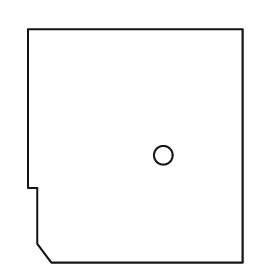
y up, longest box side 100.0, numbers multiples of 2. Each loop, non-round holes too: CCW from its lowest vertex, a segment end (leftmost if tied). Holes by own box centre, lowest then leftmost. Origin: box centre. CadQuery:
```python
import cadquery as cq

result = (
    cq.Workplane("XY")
    .moveTo(-36.0, -50.0)
    .lineTo(46.0, -50.0)
    .lineTo(46.0, 50.0)
    .lineTo(-46.0, 50.0)
    .lineTo(-46.0, -18.0)
    .lineTo(-42.0, -18.0)
    .lineTo(-42.0, -42.0)
    .close()
    .moveTo(12.0, -4.0)
    .circle(4.0)
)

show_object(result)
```